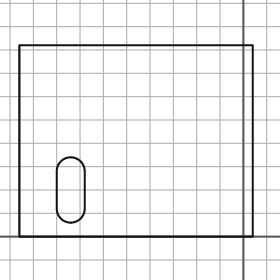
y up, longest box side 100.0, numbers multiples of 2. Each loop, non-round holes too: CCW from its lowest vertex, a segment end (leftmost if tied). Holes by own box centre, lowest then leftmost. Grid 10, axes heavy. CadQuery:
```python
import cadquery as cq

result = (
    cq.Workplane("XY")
    .moveTo(-96.0, 0.0)
    .lineTo(4.0, 0.0)
    .lineTo(4.0, 82.0)
    .lineTo(-96.0, 82.0)
    .close()
    .moveTo(-80.0, 12.0)
    .threePointArc((-74.0, 6.0), (-68.0, 12.0))
    .lineTo(-68.0, 28.0)
    .threePointArc((-74.0, 34.0), (-80.0, 28.0))
    .close()
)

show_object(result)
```